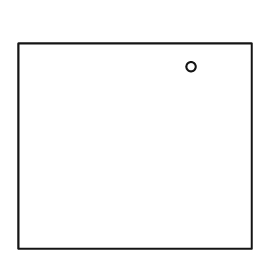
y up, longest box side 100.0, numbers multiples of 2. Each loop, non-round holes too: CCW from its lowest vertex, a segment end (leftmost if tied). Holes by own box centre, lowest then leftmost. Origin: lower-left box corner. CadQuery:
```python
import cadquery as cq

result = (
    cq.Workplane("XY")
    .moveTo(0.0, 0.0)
    .lineTo(100.0, 0.0)
    .lineTo(100.0, 88.0)
    .lineTo(0.0, 88.0)
    .close()
    .moveTo(74.0, 78.0)
    .circle(2.0)
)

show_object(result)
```